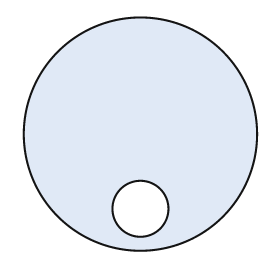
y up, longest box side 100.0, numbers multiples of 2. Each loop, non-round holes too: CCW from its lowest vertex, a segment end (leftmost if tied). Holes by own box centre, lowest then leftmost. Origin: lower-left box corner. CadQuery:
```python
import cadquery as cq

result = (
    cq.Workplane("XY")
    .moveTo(50.0, 50.0)
    .circle(50.0)
    .moveTo(50.0, 18.0)
    .circle(12.0)
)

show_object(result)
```